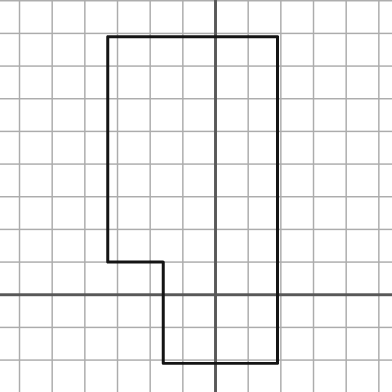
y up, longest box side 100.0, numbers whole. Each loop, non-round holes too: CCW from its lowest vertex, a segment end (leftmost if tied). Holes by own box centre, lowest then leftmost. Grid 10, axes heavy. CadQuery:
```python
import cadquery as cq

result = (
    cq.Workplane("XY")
    .moveTo(-16.0, -21.0)
    .lineTo(19.0, -21.0)
    .lineTo(19.0, 79.0)
    .lineTo(-33.0, 79.0)
    .lineTo(-33.0, 10.0)
    .lineTo(-16.0, 10.0)
    .close()
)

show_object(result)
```